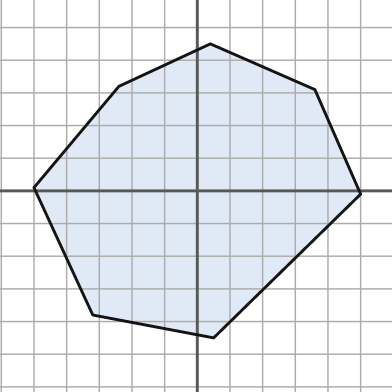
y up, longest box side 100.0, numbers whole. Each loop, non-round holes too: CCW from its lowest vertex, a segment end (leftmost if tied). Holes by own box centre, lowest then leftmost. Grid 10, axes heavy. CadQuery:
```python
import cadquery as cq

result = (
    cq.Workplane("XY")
    .moveTo(5.0, -45.0)
    .lineTo(50.0, -1.0)
    .lineTo(36.0, 31.0)
    .lineTo(4.0, 45.0)
    .lineTo(-24.0, 32.0)
    .lineTo(-50.0, 1.0)
    .lineTo(-32.0, -38.0)
    .close()
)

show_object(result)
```